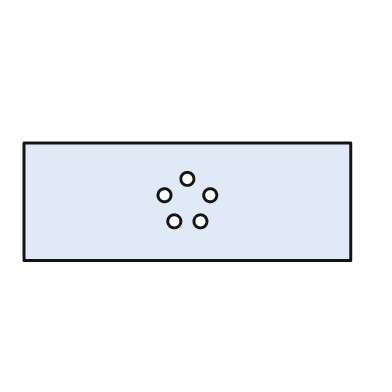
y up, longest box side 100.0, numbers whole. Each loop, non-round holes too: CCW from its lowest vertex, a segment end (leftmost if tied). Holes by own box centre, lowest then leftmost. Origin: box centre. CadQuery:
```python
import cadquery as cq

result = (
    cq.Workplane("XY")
    .moveTo(-50.0, -18.0)
    .lineTo(50.0, -18.0)
    .lineTo(50.0, 18.0)
    .lineTo(-50.0, 18.0)
    .close()
    .moveTo(-4.0, -6.0)
    .circle(2.0)
    .moveTo(4.0, -6.0)
    .circle(2.0)
    .moveTo(-7.0, 2.0)
    .circle(2.0)
    .moveTo(7.0, 2.0)
    .circle(2.0)
    .moveTo(0.0, 7.0)
    .circle(2.0)
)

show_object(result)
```